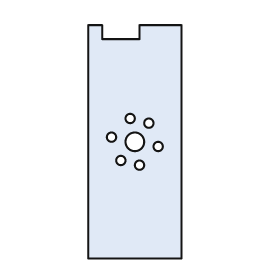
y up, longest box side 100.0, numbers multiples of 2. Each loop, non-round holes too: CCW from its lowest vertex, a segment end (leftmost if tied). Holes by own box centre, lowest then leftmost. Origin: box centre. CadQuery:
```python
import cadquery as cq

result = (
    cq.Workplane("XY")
    .moveTo(-20.0, -50.0)
    .lineTo(20.0, -50.0)
    .lineTo(20.0, 50.0)
    .lineTo(2.0, 50.0)
    .lineTo(2.0, 44.0)
    .lineTo(-14.0, 44.0)
    .lineTo(-14.0, 50.0)
    .lineTo(-20.0, 50.0)
    .close()
    .moveTo(2.0, -10.0)
    .circle(2.0)
    .moveTo(-6.0, -8.0)
    .circle(2.0)
    .moveTo(10.0, -2.0)
    .circle(2.0)
    .moveTo(0.0, 0.0)
    .circle(4.0)
    .moveTo(-10.0, 2.0)
    .circle(2.0)
    .moveTo(6.0, 8.0)
    .circle(2.0)
    .moveTo(-2.0, 10.0)
    .circle(2.0)
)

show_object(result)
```